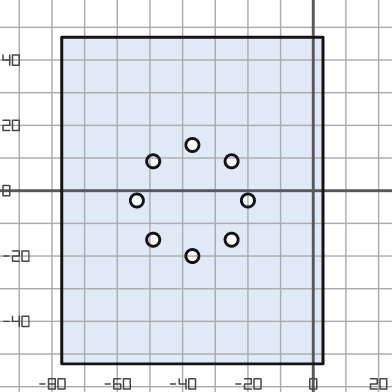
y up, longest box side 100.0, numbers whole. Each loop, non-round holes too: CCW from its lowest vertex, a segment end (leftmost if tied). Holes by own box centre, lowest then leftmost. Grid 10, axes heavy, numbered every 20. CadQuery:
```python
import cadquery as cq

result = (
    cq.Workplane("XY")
    .moveTo(-77.0, -53.0)
    .lineTo(3.0, -53.0)
    .lineTo(3.0, 47.0)
    .lineTo(-77.0, 47.0)
    .close()
    .moveTo(-37.0, -20.0)
    .circle(2.0)
    .moveTo(-49.0, -15.0)
    .circle(2.0)
    .moveTo(-25.0, -15.0)
    .circle(2.0)
    .moveTo(-54.0, -3.0)
    .circle(2.0)
    .moveTo(-20.0, -3.0)
    .circle(2.0)
    .moveTo(-49.0, 9.0)
    .circle(2.0)
    .moveTo(-25.0, 9.0)
    .circle(2.0)
    .moveTo(-37.0, 14.0)
    .circle(2.0)
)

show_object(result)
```